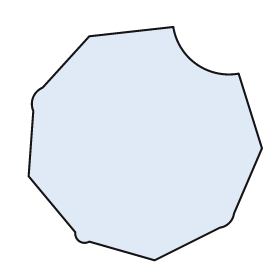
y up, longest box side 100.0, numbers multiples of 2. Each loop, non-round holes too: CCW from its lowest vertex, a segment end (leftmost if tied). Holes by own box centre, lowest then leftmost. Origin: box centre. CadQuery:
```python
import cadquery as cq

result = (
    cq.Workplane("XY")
    .moveTo(4.0, -50.0)
    .lineTo(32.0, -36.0)
    .threePointArc((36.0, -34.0), (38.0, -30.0))
    .lineTo(50.0, -2.0)
    .lineTo(40.0, 30.0)
    .threePointArc((22.0, 34.0), (12.0, 50.0))
    .lineTo(-24.0, 46.0)
    .lineTo(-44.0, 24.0)
    .threePointArc((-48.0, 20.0), (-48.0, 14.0))
    .lineTo(-50.0, -14.0)
    .lineTo(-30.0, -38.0)
    .threePointArc((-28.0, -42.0), (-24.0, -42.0))
    .close()
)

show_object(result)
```